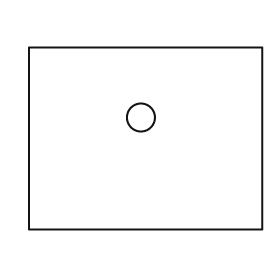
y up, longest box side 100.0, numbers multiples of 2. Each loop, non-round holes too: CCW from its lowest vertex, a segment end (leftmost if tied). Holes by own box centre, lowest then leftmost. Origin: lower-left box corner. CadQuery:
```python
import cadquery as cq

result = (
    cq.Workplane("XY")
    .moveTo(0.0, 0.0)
    .lineTo(100.0, 0.0)
    .lineTo(100.0, 78.0)
    .lineTo(0.0, 78.0)
    .close()
    .moveTo(48.0, 48.0)
    .circle(6.0)
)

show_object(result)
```